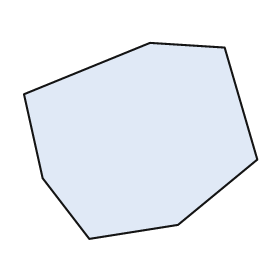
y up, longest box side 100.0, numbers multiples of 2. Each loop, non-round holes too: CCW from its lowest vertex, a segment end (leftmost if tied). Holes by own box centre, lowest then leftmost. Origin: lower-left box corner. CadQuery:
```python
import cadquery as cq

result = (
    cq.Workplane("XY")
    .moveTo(28.0, 0.0)
    .lineTo(66.0, 6.0)
    .lineTo(100.0, 34.0)
    .lineTo(86.0, 82.0)
    .lineTo(54.0, 84.0)
    .lineTo(0.0, 62.0)
    .lineTo(8.0, 26.0)
    .close()
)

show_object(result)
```